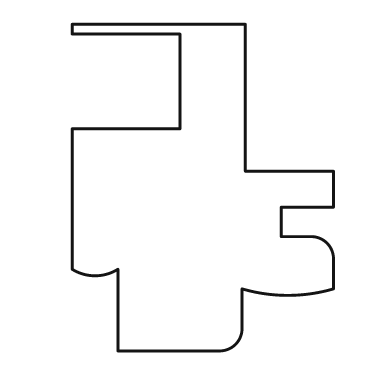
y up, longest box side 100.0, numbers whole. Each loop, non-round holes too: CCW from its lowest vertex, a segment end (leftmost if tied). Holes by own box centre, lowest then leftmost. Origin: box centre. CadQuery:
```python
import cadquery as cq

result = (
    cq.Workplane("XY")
    .moveTo(-26.0, -50.0)
    .lineTo(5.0, -50.0)
    .threePointArc((10.0, -48.0), (12.0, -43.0))
    .lineTo(12.0, -31.0)
    .threePointArc((26.0, -33.0), (40.0, -31.0))
    .lineTo(40.0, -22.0)
    .threePointArc((38.0, -17.0), (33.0, -15.0))
    .lineTo(24.0, -15.0)
    .lineTo(24.0, -6.0)
    .lineTo(40.0, -6.0)
    .lineTo(40.0, 5.0)
    .lineTo(13.0, 5.0)
    .lineTo(13.0, 50.0)
    .lineTo(-40.0, 50.0)
    .lineTo(-40.0, 47.0)
    .lineTo(-7.0, 47.0)
    .lineTo(-7.0, 18.0)
    .lineTo(-40.0, 18.0)
    .lineTo(-40.0, -25.0)
    .threePointArc((-33.0, -27.0), (-26.0, -25.0))
    .close()
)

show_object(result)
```